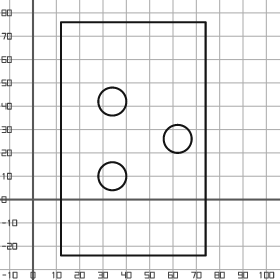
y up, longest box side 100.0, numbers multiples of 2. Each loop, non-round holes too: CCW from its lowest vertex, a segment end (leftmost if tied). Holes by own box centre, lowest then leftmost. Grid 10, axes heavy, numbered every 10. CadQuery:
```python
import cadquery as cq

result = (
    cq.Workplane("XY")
    .moveTo(12.0, -24.0)
    .lineTo(74.0, -24.0)
    .lineTo(74.0, 76.0)
    .lineTo(12.0, 76.0)
    .close()
    .moveTo(34.0, 10.0)
    .circle(6.0)
    .moveTo(62.0, 26.0)
    .circle(6.0)
    .moveTo(34.0, 42.0)
    .circle(6.0)
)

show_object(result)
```